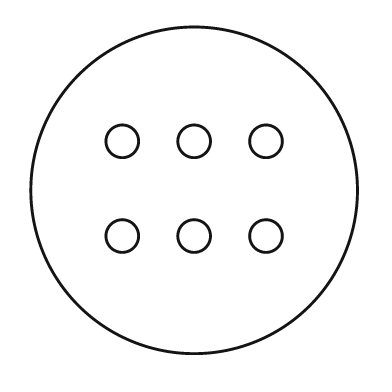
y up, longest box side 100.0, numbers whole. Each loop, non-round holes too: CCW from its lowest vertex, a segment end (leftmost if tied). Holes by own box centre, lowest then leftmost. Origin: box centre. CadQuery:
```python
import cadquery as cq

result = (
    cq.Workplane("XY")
    .moveTo(0.0, 0.0)
    .circle(50.0)
    .moveTo(-22.0, -14.0)
    .circle(5.0)
    .moveTo(0.0, -14.0)
    .circle(5.0)
    .moveTo(22.0, -14.0)
    .circle(5.0)
    .moveTo(-22.0, 15.0)
    .circle(5.0)
    .moveTo(0.0, 15.0)
    .circle(5.0)
    .moveTo(22.0, 15.0)
    .circle(5.0)
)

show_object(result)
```